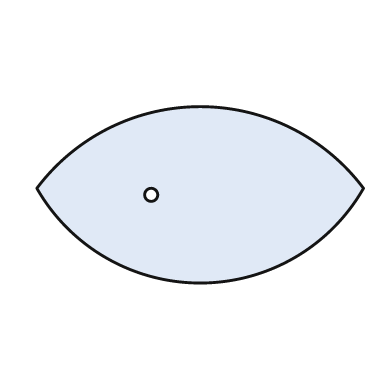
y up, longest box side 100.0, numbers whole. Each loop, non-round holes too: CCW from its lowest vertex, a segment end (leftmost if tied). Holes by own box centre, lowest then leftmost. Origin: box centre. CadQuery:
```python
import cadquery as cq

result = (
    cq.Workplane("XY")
    .moveTo(-50.0, 2.0)
    .threePointArc((0.0, -27.0), (50.0, 2.0))
    .threePointArc((0.0, 27.0), (-50.0, 2.0))
    .close()
    .moveTo(-15.0, 0.0)
    .circle(2.0)
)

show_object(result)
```